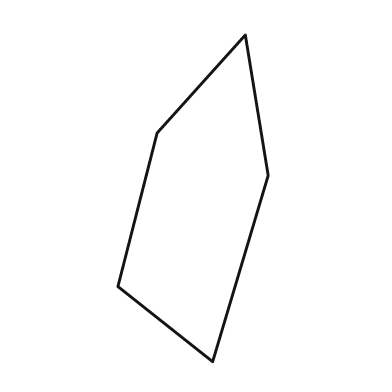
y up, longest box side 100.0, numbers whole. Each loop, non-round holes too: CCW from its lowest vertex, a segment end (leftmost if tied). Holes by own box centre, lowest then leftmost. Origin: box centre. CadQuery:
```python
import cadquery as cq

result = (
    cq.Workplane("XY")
    .moveTo(6.0, -50.0)
    .lineTo(23.0, 7.0)
    .lineTo(16.0, 50.0)
    .lineTo(-11.0, 20.0)
    .lineTo(-23.0, -27.0)
    .close()
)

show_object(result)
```